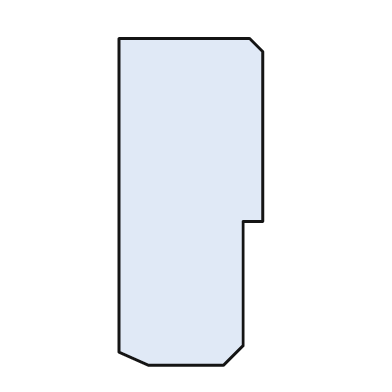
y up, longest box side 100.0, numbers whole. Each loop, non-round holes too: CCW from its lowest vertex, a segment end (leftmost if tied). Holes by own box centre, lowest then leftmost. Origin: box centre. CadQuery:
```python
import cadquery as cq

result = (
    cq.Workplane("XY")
    .moveTo(-13.0, -50.0)
    .lineTo(10.0, -50.0)
    .lineTo(16.0, -44.0)
    .lineTo(16.0, -6.0)
    .lineTo(22.0, -6.0)
    .lineTo(22.0, 46.0)
    .lineTo(18.0, 50.0)
    .lineTo(-22.0, 50.0)
    .lineTo(-22.0, -46.0)
    .close()
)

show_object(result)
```